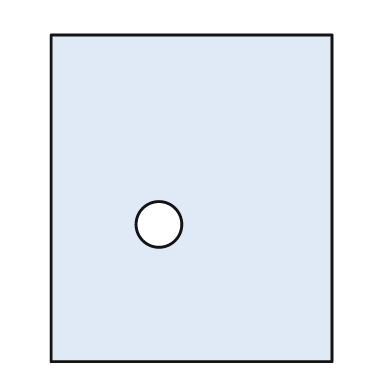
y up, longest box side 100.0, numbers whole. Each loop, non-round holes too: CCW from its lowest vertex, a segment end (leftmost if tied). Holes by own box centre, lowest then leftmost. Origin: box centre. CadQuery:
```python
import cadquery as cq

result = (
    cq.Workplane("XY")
    .moveTo(-43.0, -50.0)
    .lineTo(43.0, -50.0)
    .lineTo(43.0, 50.0)
    .lineTo(-43.0, 50.0)
    .close()
    .moveTo(-10.0, -8.0)
    .circle(7.0)
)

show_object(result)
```